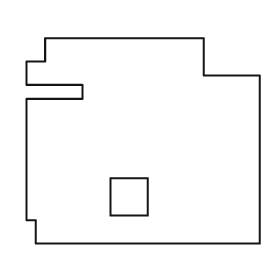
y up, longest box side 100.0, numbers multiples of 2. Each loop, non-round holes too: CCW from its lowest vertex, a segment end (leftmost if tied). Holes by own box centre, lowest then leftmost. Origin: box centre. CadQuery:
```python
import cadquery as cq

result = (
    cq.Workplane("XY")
    .moveTo(-46.0, -44.0)
    .lineTo(50.0, -44.0)
    .lineTo(50.0, 28.0)
    .lineTo(26.0, 28.0)
    .lineTo(26.0, 44.0)
    .lineTo(-42.0, 44.0)
    .lineTo(-42.0, 34.0)
    .lineTo(-50.0, 34.0)
    .lineTo(-50.0, 24.0)
    .lineTo(-26.0, 24.0)
    .lineTo(-26.0, 18.0)
    .lineTo(-50.0, 18.0)
    .lineTo(-50.0, -34.0)
    .lineTo(-46.0, -34.0)
    .close()
    .moveTo(-14.0, -32.0)
    .lineTo(2.0, -32.0)
    .lineTo(2.0, -16.0)
    .lineTo(-14.0, -16.0)
    .close()
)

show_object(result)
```